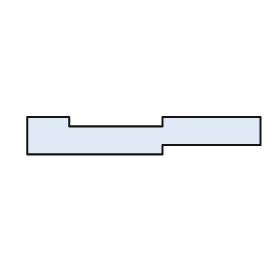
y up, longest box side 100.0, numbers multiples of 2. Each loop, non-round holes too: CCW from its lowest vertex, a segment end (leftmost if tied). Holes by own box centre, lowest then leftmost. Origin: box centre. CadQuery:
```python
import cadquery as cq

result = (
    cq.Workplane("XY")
    .moveTo(-50.0, -8.0)
    .lineTo(8.0, -8.0)
    .lineTo(8.0, -4.0)
    .lineTo(50.0, -4.0)
    .lineTo(50.0, 8.0)
    .lineTo(8.0, 8.0)
    .lineTo(8.0, 4.0)
    .lineTo(-32.0, 4.0)
    .lineTo(-32.0, 8.0)
    .lineTo(-50.0, 8.0)
    .close()
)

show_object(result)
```